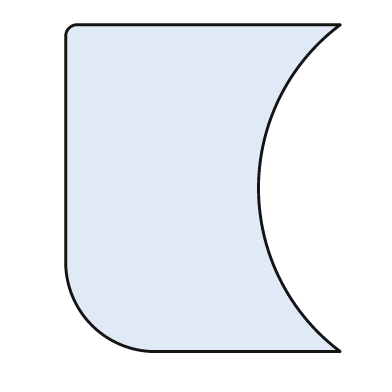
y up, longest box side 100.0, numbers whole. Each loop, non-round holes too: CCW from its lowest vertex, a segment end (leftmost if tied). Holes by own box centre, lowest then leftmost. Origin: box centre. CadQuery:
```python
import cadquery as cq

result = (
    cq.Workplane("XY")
    .moveTo(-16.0, -50.0)
    .lineTo(42.0, -50.0)
    .threePointArc((17.0, 0.0), (42.0, 50.0))
    .lineTo(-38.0, 50.0)
    .threePointArc((-41.0, 49.0), (-42.0, 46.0))
    .lineTo(-42.0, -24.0)
    .threePointArc((-34.0, -42.0), (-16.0, -50.0))
    .close()
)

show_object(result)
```